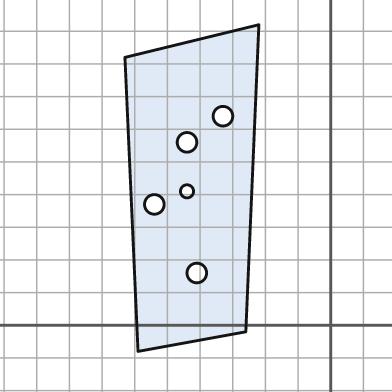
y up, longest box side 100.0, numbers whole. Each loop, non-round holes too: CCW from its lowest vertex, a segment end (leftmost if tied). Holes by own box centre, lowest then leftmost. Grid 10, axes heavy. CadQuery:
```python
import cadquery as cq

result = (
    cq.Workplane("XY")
    .moveTo(-59.0, -8.0)
    .lineTo(-26.0, -2.0)
    .lineTo(-22.0, 92.0)
    .lineTo(-63.0, 82.0)
    .close()
    .moveTo(-41.0, 16.0)
    .circle(3.0)
    .moveTo(-54.0, 37.0)
    .circle(3.0)
    .moveTo(-44.0, 41.0)
    .circle(2.0)
    .moveTo(-44.0, 56.0)
    .circle(3.0)
    .moveTo(-33.0, 64.0)
    .circle(3.0)
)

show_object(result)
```